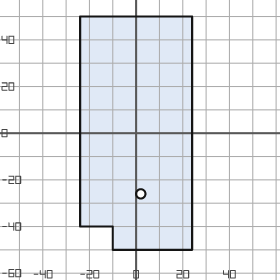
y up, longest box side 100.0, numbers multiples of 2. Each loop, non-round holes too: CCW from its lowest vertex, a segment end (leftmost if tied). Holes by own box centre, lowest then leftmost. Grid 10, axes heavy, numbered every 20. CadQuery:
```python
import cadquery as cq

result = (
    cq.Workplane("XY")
    .moveTo(-10.0, -50.0)
    .lineTo(24.0, -50.0)
    .lineTo(24.0, 50.0)
    .lineTo(-24.0, 50.0)
    .lineTo(-24.0, -40.0)
    .lineTo(-10.0, -40.0)
    .close()
    .moveTo(2.0, -26.0)
    .circle(2.0)
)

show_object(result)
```